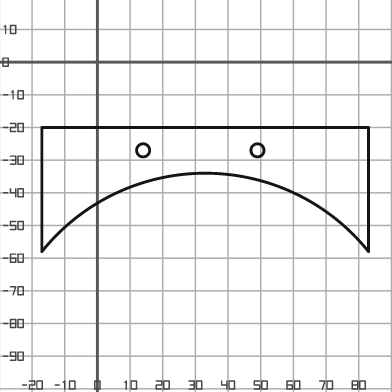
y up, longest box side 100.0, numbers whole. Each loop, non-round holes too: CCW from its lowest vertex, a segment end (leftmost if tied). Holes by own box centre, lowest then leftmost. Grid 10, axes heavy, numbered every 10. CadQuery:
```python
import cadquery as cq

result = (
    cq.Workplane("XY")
    .moveTo(-17.0, -58.0)
    .threePointArc((33.0, -34.0), (83.0, -58.0))
    .lineTo(83.0, -20.0)
    .lineTo(-17.0, -20.0)
    .close()
    .moveTo(14.0, -27.0)
    .circle(2.0)
    .moveTo(49.0, -27.0)
    .circle(2.0)
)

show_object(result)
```